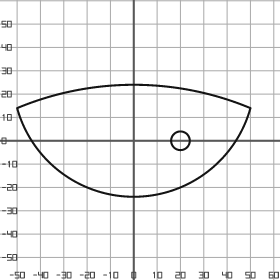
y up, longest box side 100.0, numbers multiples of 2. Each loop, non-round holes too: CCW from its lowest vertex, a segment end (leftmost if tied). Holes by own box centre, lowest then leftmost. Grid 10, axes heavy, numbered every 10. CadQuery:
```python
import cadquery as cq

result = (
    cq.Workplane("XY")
    .moveTo(-50.0, 14.0)
    .threePointArc((0.0, -24.0), (50.0, 14.0))
    .threePointArc((0.0, 24.0), (-50.0, 14.0))
    .close()
    .moveTo(20.0, 0.0)
    .circle(4.0)
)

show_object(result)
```